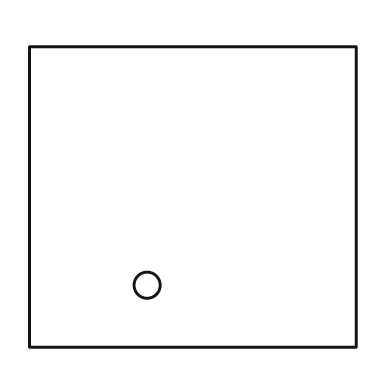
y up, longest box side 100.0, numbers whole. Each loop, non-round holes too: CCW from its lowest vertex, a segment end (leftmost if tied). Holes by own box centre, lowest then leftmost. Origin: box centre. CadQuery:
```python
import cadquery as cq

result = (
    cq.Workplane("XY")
    .moveTo(-50.0, -46.0)
    .lineTo(50.0, -46.0)
    .lineTo(50.0, 46.0)
    .lineTo(-50.0, 46.0)
    .close()
    .moveTo(-14.0, -27.0)
    .circle(4.0)
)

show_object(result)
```